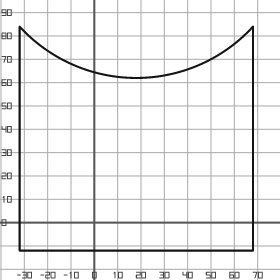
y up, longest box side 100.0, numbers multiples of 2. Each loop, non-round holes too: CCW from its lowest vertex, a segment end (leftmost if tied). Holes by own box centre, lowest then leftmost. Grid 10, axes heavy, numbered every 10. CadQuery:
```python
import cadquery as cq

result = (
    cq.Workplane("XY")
    .moveTo(-32.0, -12.0)
    .lineTo(68.0, -12.0)
    .lineTo(68.0, 84.0)
    .threePointArc((18.0, 62.0), (-32.0, 84.0))
    .close()
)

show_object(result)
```